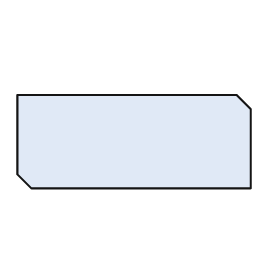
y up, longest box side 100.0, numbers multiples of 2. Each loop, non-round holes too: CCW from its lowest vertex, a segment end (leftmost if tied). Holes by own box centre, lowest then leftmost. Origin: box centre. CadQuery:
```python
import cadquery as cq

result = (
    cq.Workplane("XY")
    .moveTo(-44.0, -20.0)
    .lineTo(50.0, -20.0)
    .lineTo(50.0, 14.0)
    .lineTo(44.0, 20.0)
    .lineTo(-50.0, 20.0)
    .lineTo(-50.0, -14.0)
    .close()
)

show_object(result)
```